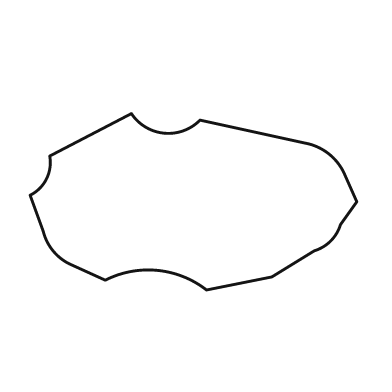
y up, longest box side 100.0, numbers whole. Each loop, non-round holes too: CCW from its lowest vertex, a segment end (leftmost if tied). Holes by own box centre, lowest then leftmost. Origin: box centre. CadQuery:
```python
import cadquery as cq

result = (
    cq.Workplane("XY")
    .moveTo(4.0, -27.0)
    .lineTo(24.0, -23.0)
    .lineTo(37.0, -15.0)
    .threePointArc((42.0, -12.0), (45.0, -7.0))
    .lineTo(50.0, 0.0)
    .lineTo(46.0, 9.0)
    .threePointArc((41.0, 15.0), (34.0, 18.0))
    .lineTo(2.0, 25.0)
    .threePointArc((-9.0, 21.0), (-19.0, 27.0))
    .lineTo(-44.0, 14.0)
    .threePointArc((-45.0, 7.0), (-50.0, 2.0))
    .lineTo(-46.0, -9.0)
    .threePointArc((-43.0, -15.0), (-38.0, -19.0))
    .lineTo(-27.0, -24.0)
    .threePointArc((-11.0, -21.0), (4.0, -27.0))
    .close()
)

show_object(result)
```